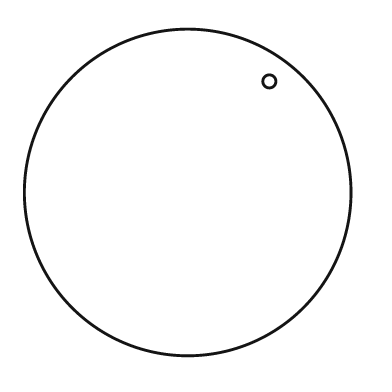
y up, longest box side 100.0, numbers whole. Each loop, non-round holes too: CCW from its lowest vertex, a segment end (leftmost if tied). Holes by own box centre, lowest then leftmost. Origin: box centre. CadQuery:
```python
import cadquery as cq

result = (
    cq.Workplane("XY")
    .moveTo(0.0, 0.0)
    .circle(50.0)
    .moveTo(25.0, 34.0)
    .circle(2.0)
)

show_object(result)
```